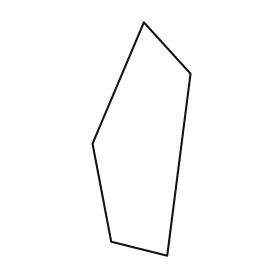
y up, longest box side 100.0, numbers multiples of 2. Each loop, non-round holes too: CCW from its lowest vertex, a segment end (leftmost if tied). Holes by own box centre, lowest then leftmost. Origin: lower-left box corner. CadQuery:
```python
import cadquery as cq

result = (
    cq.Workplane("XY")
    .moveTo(32.0, 0.0)
    .lineTo(42.0, 78.0)
    .lineTo(22.0, 100.0)
    .lineTo(0.0, 48.0)
    .lineTo(8.0, 6.0)
    .close()
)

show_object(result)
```